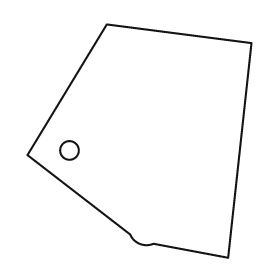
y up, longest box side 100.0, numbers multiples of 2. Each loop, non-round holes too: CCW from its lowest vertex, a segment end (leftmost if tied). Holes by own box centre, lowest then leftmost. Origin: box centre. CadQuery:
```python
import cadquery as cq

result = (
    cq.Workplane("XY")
    .moveTo(38.0, -50.0)
    .lineTo(48.0, 42.0)
    .lineTo(-14.0, 50.0)
    .lineTo(-48.0, -6.0)
    .lineTo(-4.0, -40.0)
    .threePointArc((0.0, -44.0), (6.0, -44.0))
    .close()
    .moveTo(-30.0, -4.0)
    .circle(4.0)
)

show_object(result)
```